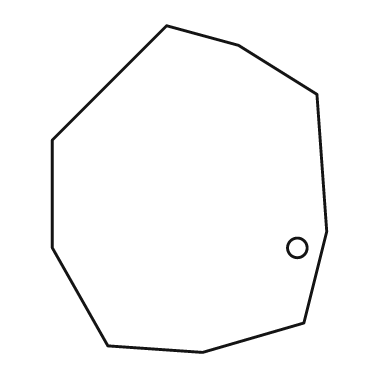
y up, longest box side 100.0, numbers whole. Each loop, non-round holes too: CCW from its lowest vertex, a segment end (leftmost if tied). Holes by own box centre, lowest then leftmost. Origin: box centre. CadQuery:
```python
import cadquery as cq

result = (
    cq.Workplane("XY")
    .moveTo(4.0, -50.0)
    .lineTo(35.0, -41.0)
    .lineTo(42.0, -13.0)
    .lineTo(39.0, 29.0)
    .lineTo(15.0, 44.0)
    .lineTo(-7.0, 50.0)
    .lineTo(-42.0, 15.0)
    .lineTo(-42.0, -18.0)
    .lineTo(-25.0, -48.0)
    .close()
    .moveTo(33.0, -18.0)
    .circle(3.0)
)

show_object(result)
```